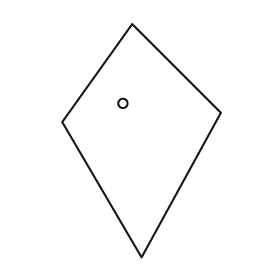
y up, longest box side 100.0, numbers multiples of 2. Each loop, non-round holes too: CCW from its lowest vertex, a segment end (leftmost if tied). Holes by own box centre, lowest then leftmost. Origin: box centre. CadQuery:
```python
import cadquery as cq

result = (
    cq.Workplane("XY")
    .moveTo(0.0, -50.0)
    .lineTo(34.0, 12.0)
    .lineTo(-4.0, 50.0)
    .lineTo(-34.0, 8.0)
    .close()
    .moveTo(-8.0, 16.0)
    .circle(2.0)
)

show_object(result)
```